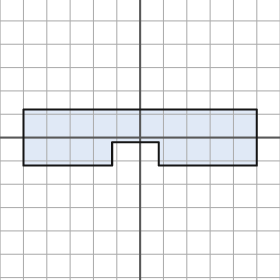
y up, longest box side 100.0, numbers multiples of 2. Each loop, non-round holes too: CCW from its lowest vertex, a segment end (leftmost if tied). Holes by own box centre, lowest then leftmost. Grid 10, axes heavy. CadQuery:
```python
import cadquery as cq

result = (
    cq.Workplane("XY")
    .moveTo(-50.0, -12.0)
    .lineTo(-12.0, -12.0)
    .lineTo(-12.0, -2.0)
    .lineTo(8.0, -2.0)
    .lineTo(8.0, -12.0)
    .lineTo(50.0, -12.0)
    .lineTo(50.0, 12.0)
    .lineTo(-50.0, 12.0)
    .close()
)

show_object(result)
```